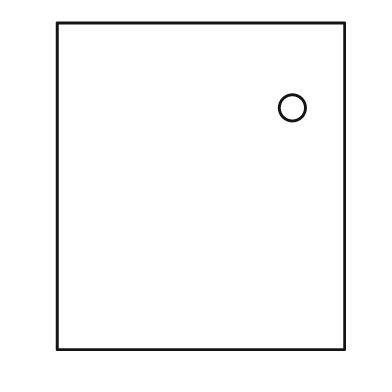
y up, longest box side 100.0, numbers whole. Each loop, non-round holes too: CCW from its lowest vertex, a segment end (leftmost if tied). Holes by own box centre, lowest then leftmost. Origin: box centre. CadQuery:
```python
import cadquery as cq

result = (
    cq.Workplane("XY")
    .moveTo(-44.0, -50.0)
    .lineTo(44.0, -50.0)
    .lineTo(44.0, 50.0)
    .lineTo(-44.0, 50.0)
    .close()
    .moveTo(28.0, 24.0)
    .circle(4.0)
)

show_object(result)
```